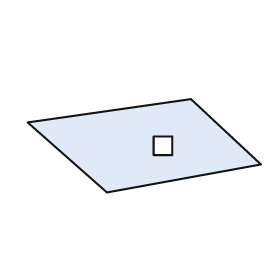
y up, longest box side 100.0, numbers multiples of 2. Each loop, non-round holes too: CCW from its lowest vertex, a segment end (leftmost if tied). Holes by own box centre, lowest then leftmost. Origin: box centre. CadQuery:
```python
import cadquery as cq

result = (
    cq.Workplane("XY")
    .moveTo(-16.0, -20.0)
    .lineTo(50.0, -8.0)
    .lineTo(20.0, 20.0)
    .lineTo(-50.0, 10.0)
    .close()
    .moveTo(4.0, -4.0)
    .lineTo(12.0, -4.0)
    .lineTo(12.0, 4.0)
    .lineTo(4.0, 4.0)
    .close()
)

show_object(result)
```